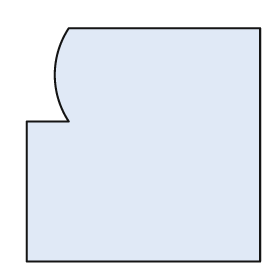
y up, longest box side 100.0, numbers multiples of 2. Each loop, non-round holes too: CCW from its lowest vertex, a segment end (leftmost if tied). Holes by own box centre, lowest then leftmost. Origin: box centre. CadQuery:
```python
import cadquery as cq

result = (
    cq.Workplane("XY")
    .moveTo(-50.0, -50.0)
    .lineTo(50.0, -50.0)
    .lineTo(50.0, 50.0)
    .lineTo(-32.0, 50.0)
    .threePointArc((-38.0, 30.0), (-32.0, 10.0))
    .lineTo(-50.0, 10.0)
    .close()
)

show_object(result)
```